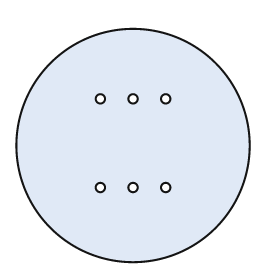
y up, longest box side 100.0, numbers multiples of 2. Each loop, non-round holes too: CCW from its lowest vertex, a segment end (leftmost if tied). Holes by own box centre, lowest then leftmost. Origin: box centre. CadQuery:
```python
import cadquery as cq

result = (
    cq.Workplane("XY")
    .moveTo(0.0, 0.0)
    .circle(50.0)
    .moveTo(-14.0, -18.0)
    .circle(2.0)
    .moveTo(0.0, -18.0)
    .circle(2.0)
    .moveTo(14.0, -18.0)
    .circle(2.0)
    .moveTo(-14.0, 20.0)
    .circle(2.0)
    .moveTo(0.0, 20.0)
    .circle(2.0)
    .moveTo(14.0, 20.0)
    .circle(2.0)
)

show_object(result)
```